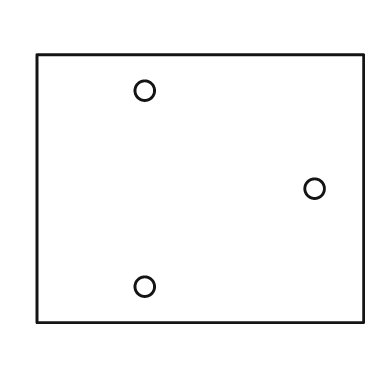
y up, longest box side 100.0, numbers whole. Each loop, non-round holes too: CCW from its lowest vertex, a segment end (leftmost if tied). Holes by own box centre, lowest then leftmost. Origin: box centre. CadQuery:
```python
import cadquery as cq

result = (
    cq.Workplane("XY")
    .moveTo(-50.0, -41.0)
    .lineTo(50.0, -41.0)
    .lineTo(50.0, 41.0)
    .lineTo(-50.0, 41.0)
    .close()
    .moveTo(-17.0, -30.0)
    .circle(3.0)
    .moveTo(35.0, 0.0)
    .circle(3.0)
    .moveTo(-17.0, 30.0)
    .circle(3.0)
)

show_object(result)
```